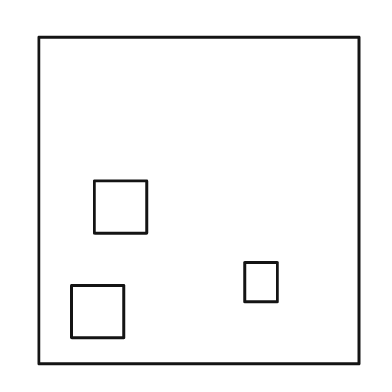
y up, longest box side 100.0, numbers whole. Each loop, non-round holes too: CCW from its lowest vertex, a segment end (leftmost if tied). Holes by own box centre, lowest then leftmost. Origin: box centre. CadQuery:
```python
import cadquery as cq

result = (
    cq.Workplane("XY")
    .moveTo(-49.0, -50.0)
    .lineTo(49.0, -50.0)
    .lineTo(49.0, 50.0)
    .lineTo(-49.0, 50.0)
    .close()
    .moveTo(-39.0, -42.0)
    .lineTo(-23.0, -42.0)
    .lineTo(-23.0, -26.0)
    .lineTo(-39.0, -26.0)
    .close()
    .moveTo(14.0, -31.0)
    .lineTo(24.0, -31.0)
    .lineTo(24.0, -19.0)
    .lineTo(14.0, -19.0)
    .close()
    .moveTo(-32.0, -10.0)
    .lineTo(-16.0, -10.0)
    .lineTo(-16.0, 6.0)
    .lineTo(-32.0, 6.0)
    .close()
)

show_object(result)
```